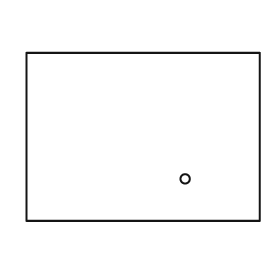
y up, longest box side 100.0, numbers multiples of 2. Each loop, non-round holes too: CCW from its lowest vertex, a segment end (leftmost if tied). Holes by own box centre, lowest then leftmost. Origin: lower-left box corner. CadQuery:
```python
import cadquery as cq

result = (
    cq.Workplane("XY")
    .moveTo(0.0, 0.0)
    .lineTo(100.0, 0.0)
    .lineTo(100.0, 72.0)
    .lineTo(0.0, 72.0)
    .close()
    .moveTo(68.0, 18.0)
    .circle(2.0)
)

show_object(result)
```